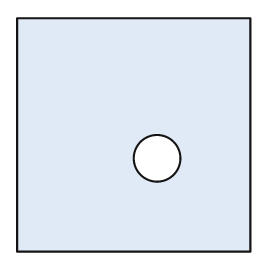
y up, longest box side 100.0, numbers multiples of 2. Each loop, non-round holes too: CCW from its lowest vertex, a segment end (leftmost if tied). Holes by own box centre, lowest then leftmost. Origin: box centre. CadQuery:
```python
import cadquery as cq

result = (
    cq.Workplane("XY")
    .moveTo(-50.0, -50.0)
    .lineTo(50.0, -50.0)
    .lineTo(50.0, 50.0)
    .lineTo(-50.0, 50.0)
    .close()
    .moveTo(10.0, -10.0)
    .circle(10.0)
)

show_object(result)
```